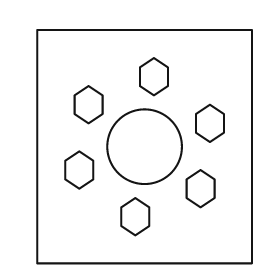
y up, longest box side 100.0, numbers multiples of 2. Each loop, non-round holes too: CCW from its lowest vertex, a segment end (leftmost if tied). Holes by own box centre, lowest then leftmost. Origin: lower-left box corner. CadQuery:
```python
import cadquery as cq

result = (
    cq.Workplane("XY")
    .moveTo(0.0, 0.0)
    .lineTo(92.0, 0.0)
    .lineTo(92.0, 100.0)
    .lineTo(0.0, 100.0)
    .close()
    .moveTo(42.0, 12.0)
    .lineTo(48.0, 16.0)
    .lineTo(48.0, 24.0)
    .lineTo(42.0, 28.0)
    .lineTo(36.0, 24.0)
    .lineTo(36.0, 16.0)
    .close()
    .moveTo(70.0, 24.0)
    .lineTo(76.0, 28.0)
    .lineTo(76.0, 36.0)
    .lineTo(70.0, 40.0)
    .lineTo(64.0, 36.0)
    .lineTo(64.0, 28.0)
    .close()
    .moveTo(18.0, 32.0)
    .lineTo(24.0, 36.0)
    .lineTo(24.0, 44.0)
    .lineTo(18.0, 48.0)
    .lineTo(12.0, 44.0)
    .lineTo(12.0, 36.0)
    .close()
    .moveTo(46.0, 50.0)
    .circle(16.0)
    .moveTo(74.0, 52.0)
    .lineTo(80.0, 56.0)
    .lineTo(80.0, 64.0)
    .lineTo(74.0, 68.0)
    .lineTo(68.0, 64.0)
    .lineTo(68.0, 56.0)
    .close()
    .moveTo(22.0, 60.0)
    .lineTo(28.0, 64.0)
    .lineTo(28.0, 72.0)
    .lineTo(22.0, 76.0)
    .lineTo(16.0, 72.0)
    .lineTo(16.0, 64.0)
    .close()
    .moveTo(50.0, 72.0)
    .lineTo(56.0, 76.0)
    .lineTo(56.0, 84.0)
    .lineTo(50.0, 88.0)
    .lineTo(44.0, 84.0)
    .lineTo(44.0, 76.0)
    .close()
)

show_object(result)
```